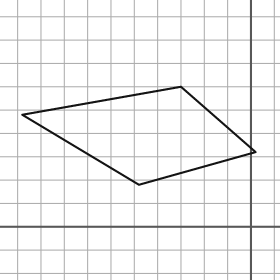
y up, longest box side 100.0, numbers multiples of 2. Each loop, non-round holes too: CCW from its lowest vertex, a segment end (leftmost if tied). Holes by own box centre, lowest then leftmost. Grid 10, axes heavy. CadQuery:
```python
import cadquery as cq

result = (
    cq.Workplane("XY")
    .moveTo(-48.0, 18.0)
    .lineTo(2.0, 32.0)
    .lineTo(-30.0, 60.0)
    .lineTo(-98.0, 48.0)
    .close()
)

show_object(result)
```